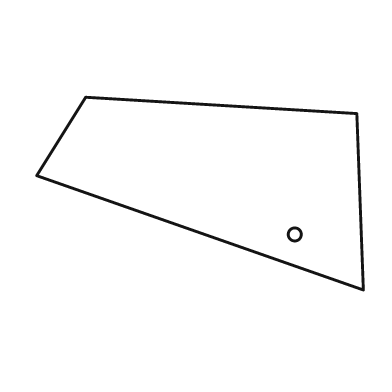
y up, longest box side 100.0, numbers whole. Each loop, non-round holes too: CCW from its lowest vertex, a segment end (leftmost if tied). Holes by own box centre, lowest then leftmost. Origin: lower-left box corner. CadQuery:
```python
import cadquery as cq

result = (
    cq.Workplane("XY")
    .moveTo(100.0, 0.0)
    .lineTo(98.0, 54.0)
    .lineTo(15.0, 59.0)
    .lineTo(0.0, 35.0)
    .close()
    .moveTo(79.0, 17.0)
    .circle(2.0)
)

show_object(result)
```